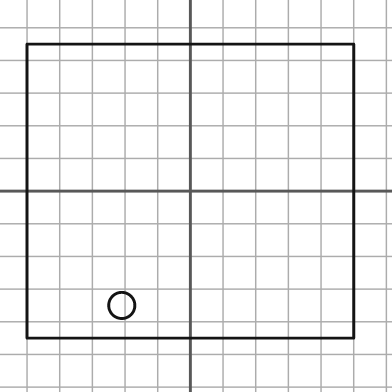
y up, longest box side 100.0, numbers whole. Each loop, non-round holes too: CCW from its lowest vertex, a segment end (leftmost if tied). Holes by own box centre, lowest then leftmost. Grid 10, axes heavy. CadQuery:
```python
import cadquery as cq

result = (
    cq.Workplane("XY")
    .moveTo(-50.0, -45.0)
    .lineTo(50.0, -45.0)
    .lineTo(50.0, 45.0)
    .lineTo(-50.0, 45.0)
    .close()
    .moveTo(-21.0, -35.0)
    .circle(4.0)
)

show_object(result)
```